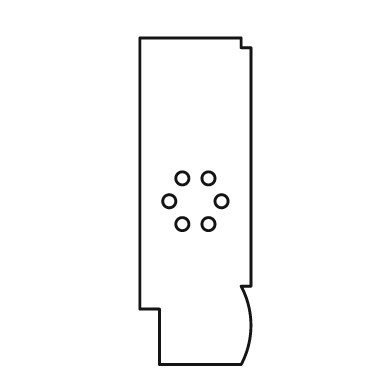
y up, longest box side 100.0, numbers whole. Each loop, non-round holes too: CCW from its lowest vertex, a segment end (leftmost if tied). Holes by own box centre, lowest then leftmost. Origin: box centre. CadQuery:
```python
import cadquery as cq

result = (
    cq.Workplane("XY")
    .moveTo(-11.0, -50.0)
    .lineTo(14.0, -50.0)
    .threePointArc((17.0, -38.0), (14.0, -26.0))
    .lineTo(17.0, -26.0)
    .lineTo(17.0, 47.0)
    .lineTo(14.0, 47.0)
    .lineTo(14.0, 50.0)
    .lineTo(-17.0, 50.0)
    .lineTo(-17.0, -33.0)
    .lineTo(-11.0, -33.0)
    .close()
    .moveTo(-4.0, -7.0)
    .circle(2.0)
    .moveTo(4.0, -7.0)
    .circle(2.0)
    .moveTo(-8.0, 0.0)
    .circle(2.0)
    .moveTo(8.0, 0.0)
    .circle(2.0)
    .moveTo(-4.0, 7.0)
    .circle(2.0)
    .moveTo(4.0, 7.0)
    .circle(2.0)
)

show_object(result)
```